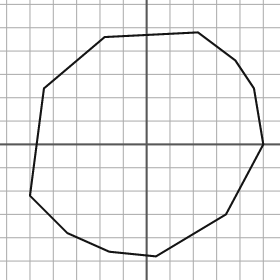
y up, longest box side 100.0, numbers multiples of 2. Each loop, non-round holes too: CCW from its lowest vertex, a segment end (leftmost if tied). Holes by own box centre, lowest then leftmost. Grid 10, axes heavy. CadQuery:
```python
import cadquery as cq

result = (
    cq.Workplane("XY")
    .moveTo(4.0, -48.0)
    .lineTo(34.0, -30.0)
    .lineTo(50.0, 0.0)
    .lineTo(46.0, 24.0)
    .lineTo(38.0, 36.0)
    .lineTo(22.0, 48.0)
    .lineTo(-18.0, 46.0)
    .lineTo(-44.0, 24.0)
    .lineTo(-50.0, -22.0)
    .lineTo(-34.0, -38.0)
    .lineTo(-16.0, -46.0)
    .close()
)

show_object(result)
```